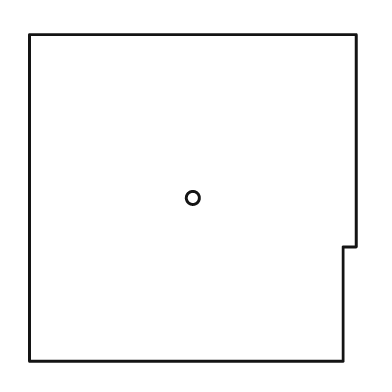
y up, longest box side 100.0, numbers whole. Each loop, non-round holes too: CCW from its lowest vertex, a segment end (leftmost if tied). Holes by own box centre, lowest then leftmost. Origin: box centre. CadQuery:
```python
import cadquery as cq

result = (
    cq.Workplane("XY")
    .moveTo(-50.0, -50.0)
    .lineTo(46.0, -50.0)
    .lineTo(46.0, -15.0)
    .lineTo(50.0, -15.0)
    .lineTo(50.0, 50.0)
    .lineTo(-50.0, 50.0)
    .close()
    .moveTo(0.0, 0.0)
    .circle(2.0)
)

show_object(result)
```